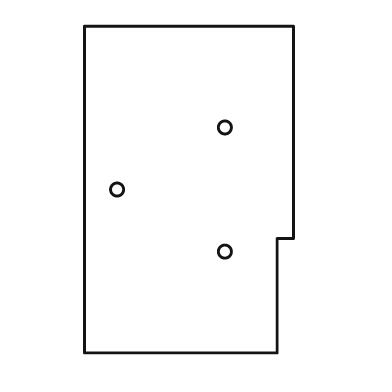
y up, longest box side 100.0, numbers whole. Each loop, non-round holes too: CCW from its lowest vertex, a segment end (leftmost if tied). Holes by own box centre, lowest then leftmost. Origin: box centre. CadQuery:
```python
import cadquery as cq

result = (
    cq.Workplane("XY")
    .moveTo(-32.0, -50.0)
    .lineTo(27.0, -50.0)
    .lineTo(27.0, -15.0)
    .lineTo(32.0, -15.0)
    .lineTo(32.0, 50.0)
    .lineTo(-32.0, 50.0)
    .close()
    .moveTo(11.0, -19.0)
    .circle(2.0)
    .moveTo(-22.0, 0.0)
    .circle(2.0)
    .moveTo(11.0, 19.0)
    .circle(2.0)
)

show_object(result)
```